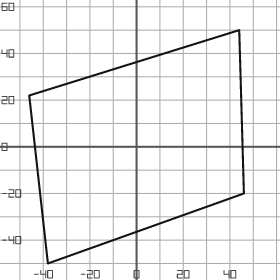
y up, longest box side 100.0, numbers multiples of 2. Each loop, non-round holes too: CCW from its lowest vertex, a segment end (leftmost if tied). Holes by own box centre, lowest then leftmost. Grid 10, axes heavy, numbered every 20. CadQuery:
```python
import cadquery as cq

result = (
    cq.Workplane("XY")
    .moveTo(-38.0, -50.0)
    .lineTo(46.0, -20.0)
    .lineTo(44.0, 50.0)
    .lineTo(-46.0, 22.0)
    .close()
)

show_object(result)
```